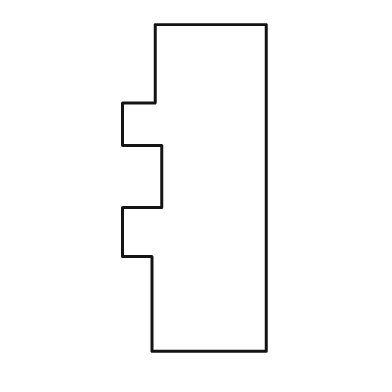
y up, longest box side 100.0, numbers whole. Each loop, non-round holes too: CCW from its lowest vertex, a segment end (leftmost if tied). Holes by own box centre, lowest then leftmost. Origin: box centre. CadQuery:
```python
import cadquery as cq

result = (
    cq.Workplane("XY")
    .moveTo(-13.0, -50.0)
    .lineTo(22.0, -50.0)
    .lineTo(22.0, 50.0)
    .lineTo(-12.0, 50.0)
    .lineTo(-12.0, 26.0)
    .lineTo(-22.0, 26.0)
    .lineTo(-22.0, 13.0)
    .lineTo(-10.0, 13.0)
    .lineTo(-10.0, -6.0)
    .lineTo(-22.0, -6.0)
    .lineTo(-22.0, -21.0)
    .lineTo(-13.0, -21.0)
    .close()
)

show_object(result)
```